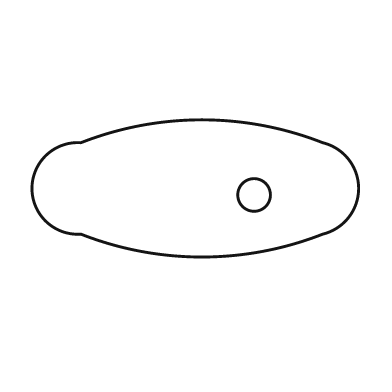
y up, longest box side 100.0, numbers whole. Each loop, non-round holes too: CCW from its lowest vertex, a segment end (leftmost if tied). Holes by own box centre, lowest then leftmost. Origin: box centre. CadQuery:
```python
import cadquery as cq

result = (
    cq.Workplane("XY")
    .moveTo(-35.0, -14.0)
    .threePointArc((2.0, -21.0), (39.0, -14.0))
    .threePointArc((50.0, 0.0), (39.0, 14.0))
    .threePointArc((2.0, 21.0), (-35.0, 14.0))
    .threePointArc((-50.0, 0.0), (-35.0, -14.0))
    .close()
    .moveTo(18.0, -2.0)
    .circle(5.0)
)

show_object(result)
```